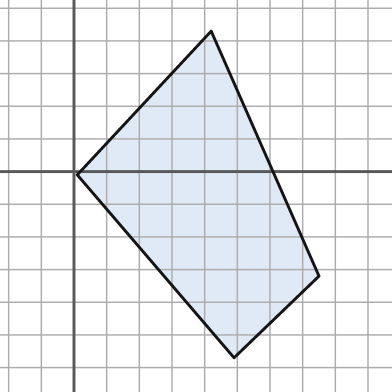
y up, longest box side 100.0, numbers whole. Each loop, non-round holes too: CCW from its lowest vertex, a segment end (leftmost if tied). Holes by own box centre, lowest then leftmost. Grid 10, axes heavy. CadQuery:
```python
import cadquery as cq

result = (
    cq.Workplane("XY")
    .moveTo(49.0, -57.0)
    .lineTo(75.0, -32.0)
    .lineTo(42.0, 43.0)
    .lineTo(1.0, -1.0)
    .close()
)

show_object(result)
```